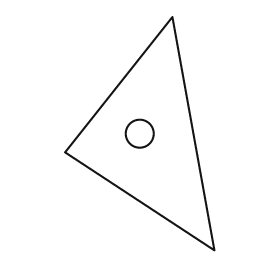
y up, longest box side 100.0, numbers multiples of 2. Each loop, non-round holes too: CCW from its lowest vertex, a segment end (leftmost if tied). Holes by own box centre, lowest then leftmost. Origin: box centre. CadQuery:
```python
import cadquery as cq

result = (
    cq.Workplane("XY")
    .moveTo(32.0, -50.0)
    .lineTo(14.0, 50.0)
    .lineTo(-32.0, -8.0)
    .close()
    .moveTo(0.0, 0.0)
    .circle(6.0)
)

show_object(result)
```